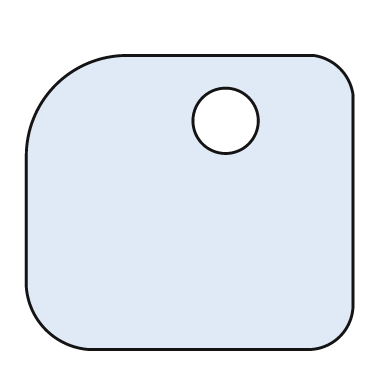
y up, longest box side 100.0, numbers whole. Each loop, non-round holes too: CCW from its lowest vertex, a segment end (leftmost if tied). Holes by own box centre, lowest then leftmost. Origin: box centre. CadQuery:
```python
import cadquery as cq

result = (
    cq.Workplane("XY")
    .moveTo(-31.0, -45.0)
    .lineTo(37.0, -45.0)
    .threePointArc((46.0, -41.0), (50.0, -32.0))
    .lineTo(50.0, 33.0)
    .threePointArc((46.0, 41.0), (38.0, 45.0))
    .lineTo(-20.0, 45.0)
    .threePointArc((-41.0, 36.0), (-50.0, 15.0))
    .lineTo(-50.0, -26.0)
    .threePointArc((-44.0, -39.0), (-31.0, -45.0))
    .close()
    .moveTo(11.0, 25.0)
    .circle(10.0)
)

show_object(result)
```